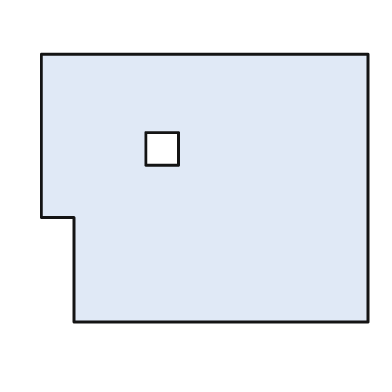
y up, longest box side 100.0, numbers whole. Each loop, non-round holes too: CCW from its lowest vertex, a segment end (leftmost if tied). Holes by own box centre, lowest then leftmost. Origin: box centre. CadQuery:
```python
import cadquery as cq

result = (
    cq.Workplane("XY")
    .moveTo(-40.0, -41.0)
    .lineTo(50.0, -41.0)
    .lineTo(50.0, 41.0)
    .lineTo(-50.0, 41.0)
    .lineTo(-50.0, -9.0)
    .lineTo(-40.0, -9.0)
    .close()
    .moveTo(-18.0, 7.0)
    .lineTo(-8.0, 7.0)
    .lineTo(-8.0, 17.0)
    .lineTo(-18.0, 17.0)
    .close()
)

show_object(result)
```